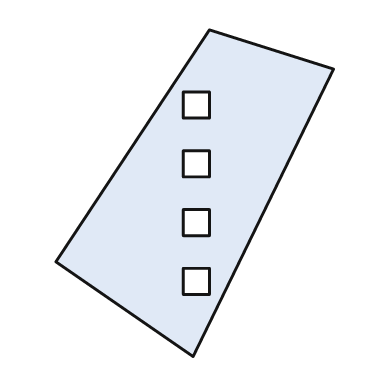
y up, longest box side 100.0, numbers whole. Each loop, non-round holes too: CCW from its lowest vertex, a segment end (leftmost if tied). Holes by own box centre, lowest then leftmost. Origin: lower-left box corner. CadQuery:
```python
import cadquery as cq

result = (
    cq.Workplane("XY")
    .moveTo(42.0, 0.0)
    .lineTo(85.0, 88.0)
    .lineTo(47.0, 100.0)
    .lineTo(0.0, 29.0)
    .close()
    .moveTo(39.0, 19.0)
    .lineTo(47.0, 19.0)
    .lineTo(47.0, 27.0)
    .lineTo(39.0, 27.0)
    .close()
    .moveTo(39.0, 37.0)
    .lineTo(47.0, 37.0)
    .lineTo(47.0, 45.0)
    .lineTo(39.0, 45.0)
    .close()
    .moveTo(39.0, 55.0)
    .lineTo(47.0, 55.0)
    .lineTo(47.0, 63.0)
    .lineTo(39.0, 63.0)
    .close()
    .moveTo(39.0, 73.0)
    .lineTo(47.0, 73.0)
    .lineTo(47.0, 81.0)
    .lineTo(39.0, 81.0)
    .close()
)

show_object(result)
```